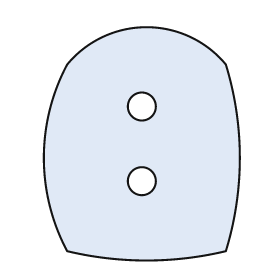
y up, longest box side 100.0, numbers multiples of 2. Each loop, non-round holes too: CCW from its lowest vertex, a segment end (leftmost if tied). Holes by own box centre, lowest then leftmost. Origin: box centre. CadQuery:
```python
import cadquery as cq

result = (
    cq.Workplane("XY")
    .moveTo(-32.0, -46.0)
    .threePointArc((2.0, -50.0), (36.0, -46.0))
    .threePointArc((42.0, -6.0), (36.0, 34.0))
    .threePointArc((2.0, 50.0), (-32.0, 34.0))
    .threePointArc((-42.0, -6.0), (-32.0, -46.0))
    .close()
    .moveTo(0.0, -16.0)
    .circle(6.0)
    .moveTo(0.0, 16.0)
    .circle(6.0)
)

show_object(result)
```